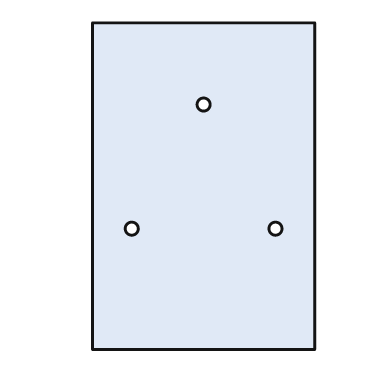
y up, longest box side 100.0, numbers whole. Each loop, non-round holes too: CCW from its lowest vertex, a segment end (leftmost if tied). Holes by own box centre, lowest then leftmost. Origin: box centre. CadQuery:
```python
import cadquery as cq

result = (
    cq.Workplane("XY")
    .moveTo(-34.0, -50.0)
    .lineTo(34.0, -50.0)
    .lineTo(34.0, 50.0)
    .lineTo(-34.0, 50.0)
    .close()
    .moveTo(-22.0, -13.0)
    .circle(2.0)
    .moveTo(22.0, -13.0)
    .circle(2.0)
    .moveTo(0.0, 25.0)
    .circle(2.0)
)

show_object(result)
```